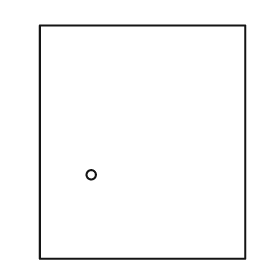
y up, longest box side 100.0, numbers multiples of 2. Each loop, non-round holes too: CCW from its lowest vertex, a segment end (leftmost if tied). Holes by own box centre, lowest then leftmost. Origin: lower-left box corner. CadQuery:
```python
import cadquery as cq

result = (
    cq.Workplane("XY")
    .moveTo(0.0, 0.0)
    .lineTo(88.0, 0.0)
    .lineTo(88.0, 100.0)
    .lineTo(0.0, 100.0)
    .close()
    .moveTo(22.0, 36.0)
    .circle(2.0)
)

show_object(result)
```